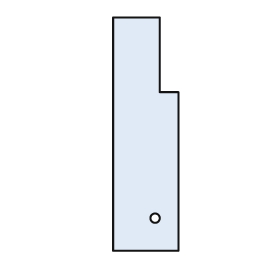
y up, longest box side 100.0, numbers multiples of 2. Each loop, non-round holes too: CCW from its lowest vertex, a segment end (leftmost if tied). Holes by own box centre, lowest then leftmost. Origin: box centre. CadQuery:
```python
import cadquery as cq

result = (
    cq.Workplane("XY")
    .moveTo(-14.0, -50.0)
    .lineTo(14.0, -50.0)
    .lineTo(14.0, 18.0)
    .lineTo(6.0, 18.0)
    .lineTo(6.0, 50.0)
    .lineTo(-14.0, 50.0)
    .close()
    .moveTo(4.0, -36.0)
    .circle(2.0)
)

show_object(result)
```